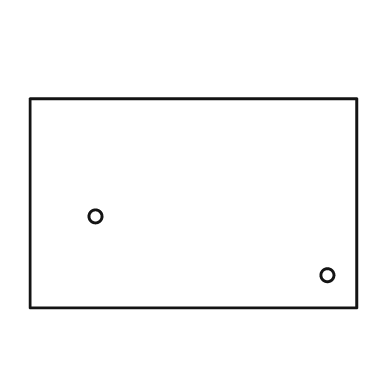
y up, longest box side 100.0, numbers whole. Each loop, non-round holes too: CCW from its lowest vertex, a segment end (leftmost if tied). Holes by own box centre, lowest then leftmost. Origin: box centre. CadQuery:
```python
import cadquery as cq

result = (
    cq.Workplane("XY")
    .moveTo(-50.0, -32.0)
    .lineTo(50.0, -32.0)
    .lineTo(50.0, 32.0)
    .lineTo(-50.0, 32.0)
    .close()
    .moveTo(41.0, -22.0)
    .circle(2.0)
    .moveTo(-30.0, -4.0)
    .circle(2.0)
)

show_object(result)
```